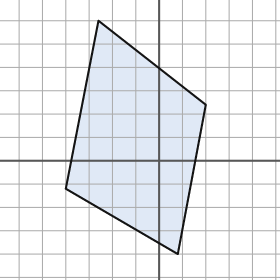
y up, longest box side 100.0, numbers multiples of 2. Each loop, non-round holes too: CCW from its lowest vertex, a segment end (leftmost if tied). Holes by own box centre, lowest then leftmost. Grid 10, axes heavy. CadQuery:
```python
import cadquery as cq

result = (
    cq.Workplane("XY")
    .moveTo(8.0, -40.0)
    .lineTo(20.0, 24.0)
    .lineTo(-26.0, 60.0)
    .lineTo(-40.0, -12.0)
    .close()
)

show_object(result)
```